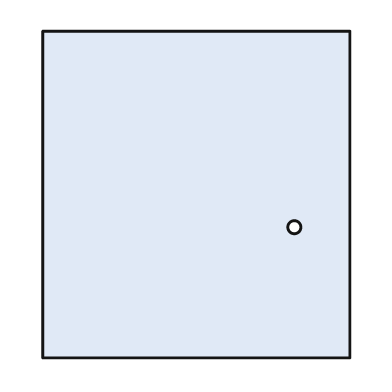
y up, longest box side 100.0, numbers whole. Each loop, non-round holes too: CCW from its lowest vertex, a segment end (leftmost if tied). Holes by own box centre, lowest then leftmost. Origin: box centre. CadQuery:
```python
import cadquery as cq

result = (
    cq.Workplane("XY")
    .moveTo(-47.0, -50.0)
    .lineTo(47.0, -50.0)
    .lineTo(47.0, 50.0)
    .lineTo(-47.0, 50.0)
    .close()
    .moveTo(30.0, -10.0)
    .circle(2.0)
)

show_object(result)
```